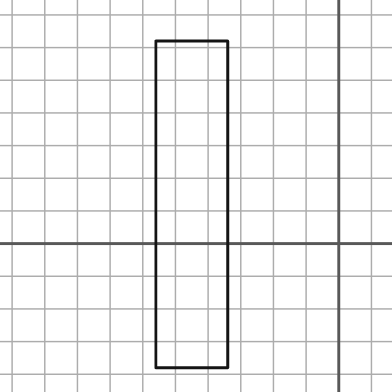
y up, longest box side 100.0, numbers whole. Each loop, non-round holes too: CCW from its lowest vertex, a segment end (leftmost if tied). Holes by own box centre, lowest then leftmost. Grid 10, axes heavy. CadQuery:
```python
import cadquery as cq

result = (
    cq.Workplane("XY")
    .moveTo(-56.0, -38.0)
    .lineTo(-34.0, -38.0)
    .lineTo(-34.0, 62.0)
    .lineTo(-56.0, 62.0)
    .close()
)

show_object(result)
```